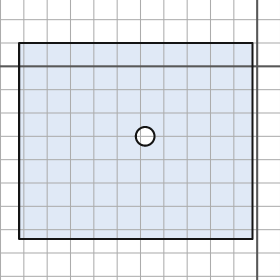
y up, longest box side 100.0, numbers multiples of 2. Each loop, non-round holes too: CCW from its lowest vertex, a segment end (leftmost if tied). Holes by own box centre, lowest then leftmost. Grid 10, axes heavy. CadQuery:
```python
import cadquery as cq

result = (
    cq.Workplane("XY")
    .moveTo(-102.0, -74.0)
    .lineTo(-2.0, -74.0)
    .lineTo(-2.0, 10.0)
    .lineTo(-102.0, 10.0)
    .close()
    .moveTo(-48.0, -30.0)
    .circle(4.0)
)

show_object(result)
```